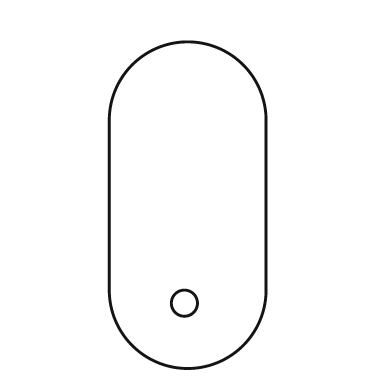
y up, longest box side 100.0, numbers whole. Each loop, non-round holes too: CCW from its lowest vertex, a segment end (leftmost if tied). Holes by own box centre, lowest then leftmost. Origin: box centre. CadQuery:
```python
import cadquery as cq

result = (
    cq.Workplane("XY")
    .moveTo(-24.0, -26.0)
    .threePointArc((0.0, -50.0), (24.0, -26.0))
    .lineTo(24.0, 26.0)
    .threePointArc((0.0, 50.0), (-24.0, 26.0))
    .close()
    .moveTo(-1.0, -30.0)
    .circle(4.0)
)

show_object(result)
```